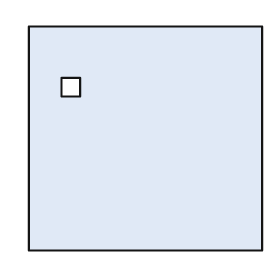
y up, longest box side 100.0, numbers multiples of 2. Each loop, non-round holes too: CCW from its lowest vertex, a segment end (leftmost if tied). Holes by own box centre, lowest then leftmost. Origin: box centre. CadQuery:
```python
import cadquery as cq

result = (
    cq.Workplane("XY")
    .moveTo(-50.0, -48.0)
    .lineTo(50.0, -48.0)
    .lineTo(50.0, 48.0)
    .lineTo(-50.0, 48.0)
    .close()
    .moveTo(-36.0, 18.0)
    .lineTo(-28.0, 18.0)
    .lineTo(-28.0, 26.0)
    .lineTo(-36.0, 26.0)
    .close()
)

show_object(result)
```